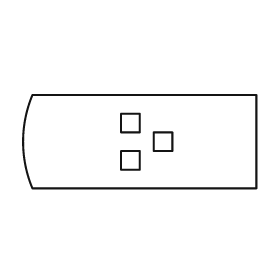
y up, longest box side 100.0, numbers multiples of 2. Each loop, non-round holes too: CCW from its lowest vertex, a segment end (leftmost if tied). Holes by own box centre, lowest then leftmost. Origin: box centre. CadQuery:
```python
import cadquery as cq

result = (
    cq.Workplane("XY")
    .moveTo(-46.0, -20.0)
    .lineTo(50.0, -20.0)
    .lineTo(50.0, 20.0)
    .lineTo(-46.0, 20.0)
    .threePointArc((-50.0, 0.0), (-46.0, -20.0))
    .close()
    .moveTo(-8.0, -12.0)
    .lineTo(0.0, -12.0)
    .lineTo(0.0, -4.0)
    .lineTo(-8.0, -4.0)
    .close()
    .moveTo(6.0, -4.0)
    .lineTo(14.0, -4.0)
    .lineTo(14.0, 4.0)
    .lineTo(6.0, 4.0)
    .close()
    .moveTo(-8.0, 4.0)
    .lineTo(0.0, 4.0)
    .lineTo(0.0, 12.0)
    .lineTo(-8.0, 12.0)
    .close()
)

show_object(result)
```